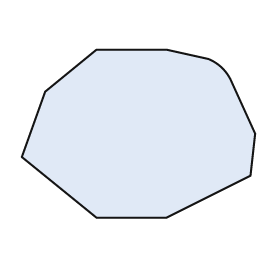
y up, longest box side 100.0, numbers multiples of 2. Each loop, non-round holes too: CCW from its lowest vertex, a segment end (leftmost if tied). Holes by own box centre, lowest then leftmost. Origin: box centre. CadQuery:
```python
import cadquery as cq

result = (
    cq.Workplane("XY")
    .moveTo(-18.0, -36.0)
    .lineTo(12.0, -36.0)
    .lineTo(48.0, -18.0)
    .lineTo(50.0, 0.0)
    .lineTo(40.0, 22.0)
    .threePointArc((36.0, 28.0), (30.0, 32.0))
    .lineTo(12.0, 36.0)
    .lineTo(-18.0, 36.0)
    .lineTo(-40.0, 18.0)
    .lineTo(-50.0, -10.0)
    .close()
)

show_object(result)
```